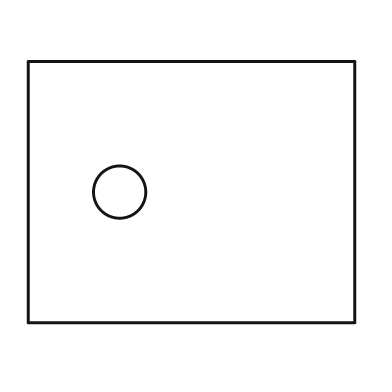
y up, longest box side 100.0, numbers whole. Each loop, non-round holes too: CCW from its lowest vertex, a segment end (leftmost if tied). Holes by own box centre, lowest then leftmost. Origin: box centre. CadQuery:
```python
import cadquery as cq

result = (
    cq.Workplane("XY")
    .moveTo(-50.0, -40.0)
    .lineTo(50.0, -40.0)
    .lineTo(50.0, 40.0)
    .lineTo(-50.0, 40.0)
    .close()
    .moveTo(-22.0, 0.0)
    .circle(8.0)
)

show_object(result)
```